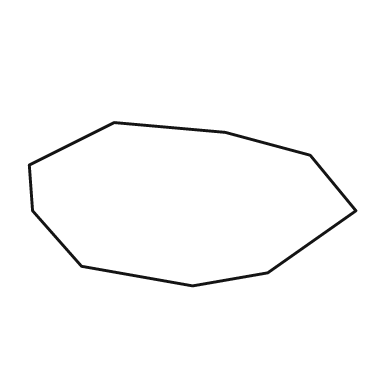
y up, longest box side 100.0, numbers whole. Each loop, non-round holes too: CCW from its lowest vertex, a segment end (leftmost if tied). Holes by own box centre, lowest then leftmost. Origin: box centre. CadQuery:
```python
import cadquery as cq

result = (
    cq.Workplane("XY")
    .moveTo(0.0, -25.0)
    .lineTo(23.0, -21.0)
    .lineTo(50.0, -2.0)
    .lineTo(36.0, 15.0)
    .lineTo(10.0, 22.0)
    .lineTo(-24.0, 25.0)
    .lineTo(-50.0, 12.0)
    .lineTo(-49.0, -2.0)
    .lineTo(-34.0, -19.0)
    .close()
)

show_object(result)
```